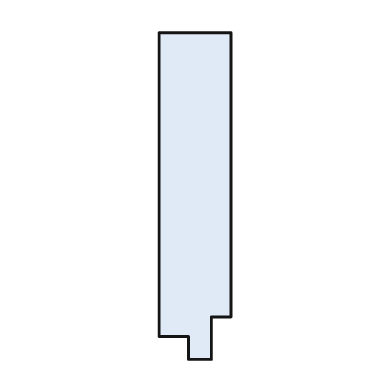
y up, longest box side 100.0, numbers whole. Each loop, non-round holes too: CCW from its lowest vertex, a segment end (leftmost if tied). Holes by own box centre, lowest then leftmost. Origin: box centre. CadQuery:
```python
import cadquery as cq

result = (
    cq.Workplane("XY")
    .moveTo(-2.0, -50.0)
    .lineTo(5.0, -50.0)
    .lineTo(5.0, -37.0)
    .lineTo(11.0, -37.0)
    .lineTo(11.0, 50.0)
    .lineTo(-11.0, 50.0)
    .lineTo(-11.0, -43.0)
    .lineTo(-2.0, -43.0)
    .close()
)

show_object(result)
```